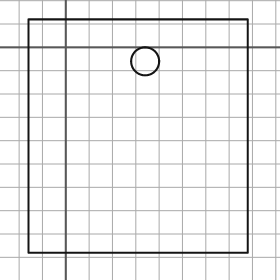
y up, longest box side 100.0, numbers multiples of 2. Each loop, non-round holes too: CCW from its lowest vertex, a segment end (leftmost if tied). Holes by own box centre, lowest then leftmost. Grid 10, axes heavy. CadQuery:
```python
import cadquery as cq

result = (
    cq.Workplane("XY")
    .moveTo(-16.0, -88.0)
    .lineTo(78.0, -88.0)
    .lineTo(78.0, 12.0)
    .lineTo(-16.0, 12.0)
    .close()
    .moveTo(34.0, -6.0)
    .circle(6.0)
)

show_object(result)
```